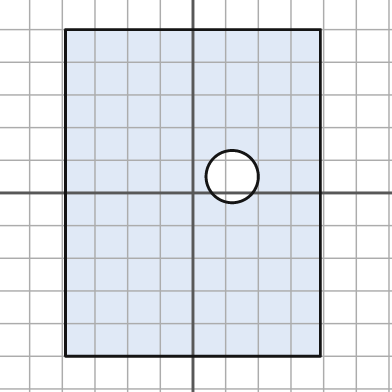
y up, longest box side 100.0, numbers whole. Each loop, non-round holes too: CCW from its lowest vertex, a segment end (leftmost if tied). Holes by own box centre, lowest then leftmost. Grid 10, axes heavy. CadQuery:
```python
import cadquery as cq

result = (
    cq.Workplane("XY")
    .moveTo(-39.0, -50.0)
    .lineTo(39.0, -50.0)
    .lineTo(39.0, 50.0)
    .lineTo(-39.0, 50.0)
    .close()
    .moveTo(12.0, 5.0)
    .circle(8.0)
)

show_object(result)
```